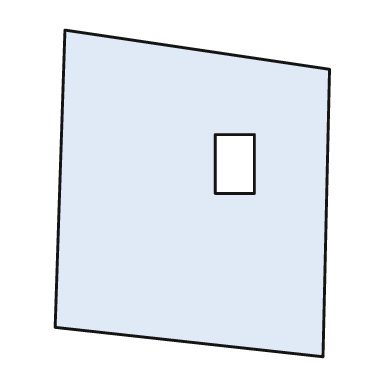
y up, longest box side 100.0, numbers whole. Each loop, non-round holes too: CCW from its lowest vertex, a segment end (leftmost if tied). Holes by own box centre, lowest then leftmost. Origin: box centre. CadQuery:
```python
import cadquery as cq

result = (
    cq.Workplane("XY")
    .moveTo(40.0, -50.0)
    .lineTo(42.0, 38.0)
    .lineTo(-39.0, 50.0)
    .lineTo(-42.0, -41.0)
    .close()
    .moveTo(7.0, 0.0)
    .lineTo(19.0, 0.0)
    .lineTo(19.0, 18.0)
    .lineTo(7.0, 18.0)
    .close()
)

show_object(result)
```